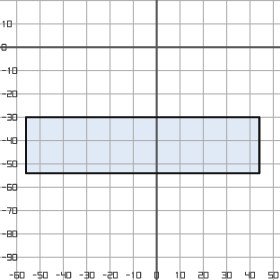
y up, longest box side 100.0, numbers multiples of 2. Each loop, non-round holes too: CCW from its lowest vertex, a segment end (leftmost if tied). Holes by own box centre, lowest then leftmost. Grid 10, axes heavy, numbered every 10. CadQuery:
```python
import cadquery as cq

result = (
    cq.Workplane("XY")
    .moveTo(-56.0, -54.0)
    .lineTo(44.0, -54.0)
    .lineTo(44.0, -30.0)
    .lineTo(-56.0, -30.0)
    .close()
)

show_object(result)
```